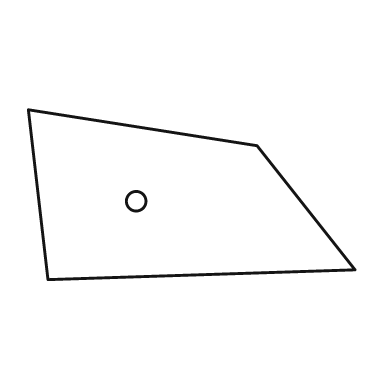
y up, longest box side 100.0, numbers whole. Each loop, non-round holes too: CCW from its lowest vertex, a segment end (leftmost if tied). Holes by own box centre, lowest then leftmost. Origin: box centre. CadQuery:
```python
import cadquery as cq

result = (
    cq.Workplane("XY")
    .moveTo(-44.0, -26.0)
    .lineTo(50.0, -23.0)
    .lineTo(20.0, 15.0)
    .lineTo(-50.0, 26.0)
    .close()
    .moveTo(-17.0, -2.0)
    .circle(3.0)
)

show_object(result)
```